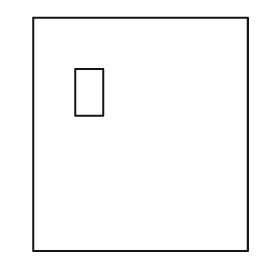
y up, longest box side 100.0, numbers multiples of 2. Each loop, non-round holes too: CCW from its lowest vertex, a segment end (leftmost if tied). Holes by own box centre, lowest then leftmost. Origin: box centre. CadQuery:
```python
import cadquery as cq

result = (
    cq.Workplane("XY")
    .moveTo(-46.0, -50.0)
    .lineTo(46.0, -50.0)
    .lineTo(46.0, 50.0)
    .lineTo(-46.0, 50.0)
    .close()
    .moveTo(-28.0, 8.0)
    .lineTo(-16.0, 8.0)
    .lineTo(-16.0, 28.0)
    .lineTo(-28.0, 28.0)
    .close()
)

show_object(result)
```